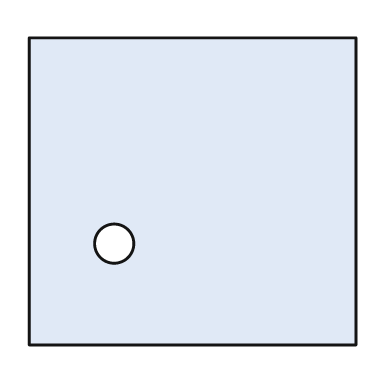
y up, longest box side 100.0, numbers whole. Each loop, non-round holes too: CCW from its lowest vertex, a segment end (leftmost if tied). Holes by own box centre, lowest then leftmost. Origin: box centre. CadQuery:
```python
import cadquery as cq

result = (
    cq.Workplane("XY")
    .moveTo(-50.0, -47.0)
    .lineTo(50.0, -47.0)
    .lineTo(50.0, 47.0)
    .lineTo(-50.0, 47.0)
    .close()
    .moveTo(-24.0, -16.0)
    .circle(6.0)
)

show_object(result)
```